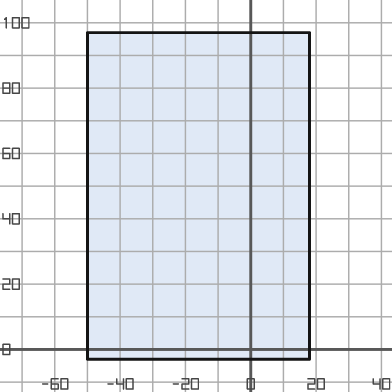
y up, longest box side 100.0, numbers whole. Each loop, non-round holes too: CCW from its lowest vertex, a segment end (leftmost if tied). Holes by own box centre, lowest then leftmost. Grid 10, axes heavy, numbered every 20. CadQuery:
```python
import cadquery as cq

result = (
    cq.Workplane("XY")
    .moveTo(-50.0, -3.0)
    .lineTo(18.0, -3.0)
    .lineTo(18.0, 97.0)
    .lineTo(-50.0, 97.0)
    .close()
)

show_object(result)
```